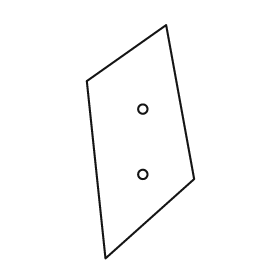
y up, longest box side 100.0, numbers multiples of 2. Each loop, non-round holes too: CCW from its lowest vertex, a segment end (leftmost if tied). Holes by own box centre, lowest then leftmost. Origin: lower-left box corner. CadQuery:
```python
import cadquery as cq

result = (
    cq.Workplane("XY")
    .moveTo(8.0, 0.0)
    .lineTo(46.0, 34.0)
    .lineTo(34.0, 100.0)
    .lineTo(0.0, 76.0)
    .close()
    .moveTo(24.0, 36.0)
    .circle(2.0)
    .moveTo(24.0, 64.0)
    .circle(2.0)
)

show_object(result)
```